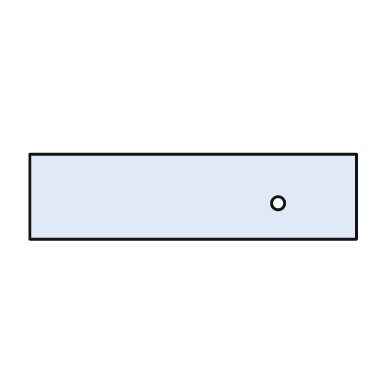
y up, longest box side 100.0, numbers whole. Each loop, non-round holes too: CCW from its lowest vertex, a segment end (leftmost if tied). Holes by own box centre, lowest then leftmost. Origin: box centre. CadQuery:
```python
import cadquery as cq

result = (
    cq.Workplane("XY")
    .moveTo(-50.0, -13.0)
    .lineTo(50.0, -13.0)
    .lineTo(50.0, 13.0)
    .lineTo(-50.0, 13.0)
    .close()
    .moveTo(26.0, -2.0)
    .circle(2.0)
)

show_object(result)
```